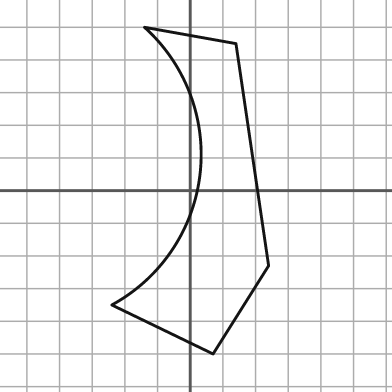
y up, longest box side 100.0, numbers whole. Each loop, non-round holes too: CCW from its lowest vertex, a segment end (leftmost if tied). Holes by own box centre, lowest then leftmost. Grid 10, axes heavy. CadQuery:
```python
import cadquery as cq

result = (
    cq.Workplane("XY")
    .moveTo(7.0, -50.0)
    .lineTo(24.0, -23.0)
    .lineTo(14.0, 45.0)
    .lineTo(-14.0, 50.0)
    .threePointArc((3.0, 5.0), (-24.0, -35.0))
    .close()
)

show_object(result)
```